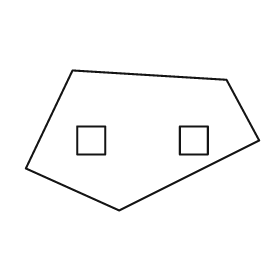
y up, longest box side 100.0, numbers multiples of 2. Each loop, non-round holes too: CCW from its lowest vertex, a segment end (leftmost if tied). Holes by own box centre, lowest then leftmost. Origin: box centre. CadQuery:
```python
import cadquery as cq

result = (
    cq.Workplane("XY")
    .moveTo(-10.0, -30.0)
    .lineTo(50.0, 0.0)
    .lineTo(36.0, 26.0)
    .lineTo(-30.0, 30.0)
    .lineTo(-50.0, -12.0)
    .close()
    .moveTo(-28.0, -6.0)
    .lineTo(-16.0, -6.0)
    .lineTo(-16.0, 6.0)
    .lineTo(-28.0, 6.0)
    .close()
    .moveTo(16.0, -6.0)
    .lineTo(28.0, -6.0)
    .lineTo(28.0, 6.0)
    .lineTo(16.0, 6.0)
    .close()
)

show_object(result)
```